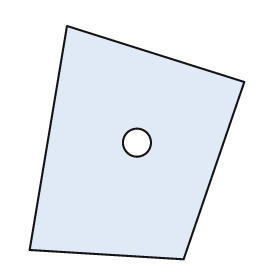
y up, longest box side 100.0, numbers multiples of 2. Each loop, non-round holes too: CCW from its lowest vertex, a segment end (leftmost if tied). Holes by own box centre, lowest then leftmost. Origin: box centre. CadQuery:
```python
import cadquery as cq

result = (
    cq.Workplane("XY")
    .moveTo(20.0, -50.0)
    .lineTo(46.0, 26.0)
    .lineTo(-30.0, 50.0)
    .lineTo(-46.0, -46.0)
    .close()
    .moveTo(0.0, 0.0)
    .circle(6.0)
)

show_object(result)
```